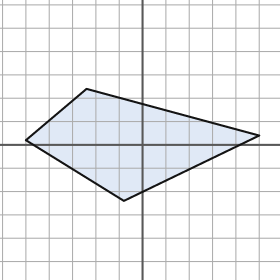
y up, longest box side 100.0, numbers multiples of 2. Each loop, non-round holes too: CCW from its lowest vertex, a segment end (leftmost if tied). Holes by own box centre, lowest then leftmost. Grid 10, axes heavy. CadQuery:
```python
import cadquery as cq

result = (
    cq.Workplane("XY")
    .moveTo(-8.0, -24.0)
    .lineTo(50.0, 4.0)
    .lineTo(-24.0, 24.0)
    .lineTo(-50.0, 2.0)
    .close()
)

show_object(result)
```